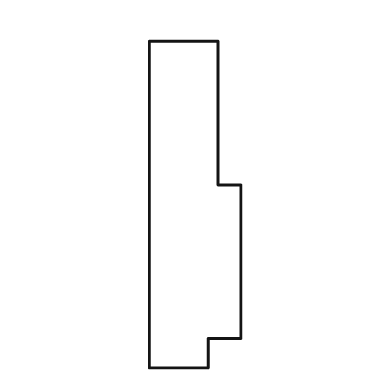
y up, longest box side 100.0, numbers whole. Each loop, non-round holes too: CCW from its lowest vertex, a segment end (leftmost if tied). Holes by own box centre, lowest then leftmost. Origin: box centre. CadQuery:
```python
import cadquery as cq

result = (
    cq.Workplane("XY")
    .moveTo(-14.0, -50.0)
    .lineTo(4.0, -50.0)
    .lineTo(4.0, -41.0)
    .lineTo(14.0, -41.0)
    .lineTo(14.0, 6.0)
    .lineTo(7.0, 6.0)
    .lineTo(7.0, 50.0)
    .lineTo(-14.0, 50.0)
    .close()
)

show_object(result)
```